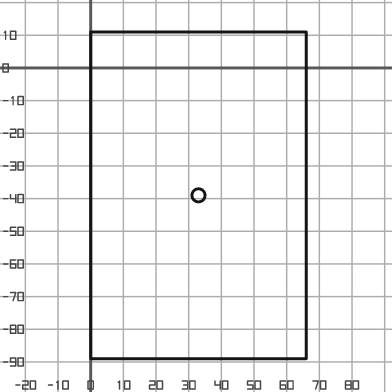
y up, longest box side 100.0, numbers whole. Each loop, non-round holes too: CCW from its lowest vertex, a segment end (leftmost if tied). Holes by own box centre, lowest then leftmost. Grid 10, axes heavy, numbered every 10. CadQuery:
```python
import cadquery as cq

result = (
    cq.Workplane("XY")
    .moveTo(0.0, -89.0)
    .lineTo(66.0, -89.0)
    .lineTo(66.0, 11.0)
    .lineTo(0.0, 11.0)
    .close()
    .moveTo(33.0, -39.0)
    .circle(2.0)
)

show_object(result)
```